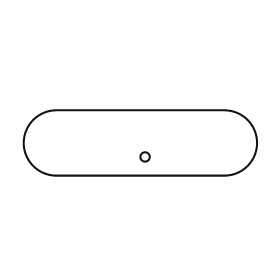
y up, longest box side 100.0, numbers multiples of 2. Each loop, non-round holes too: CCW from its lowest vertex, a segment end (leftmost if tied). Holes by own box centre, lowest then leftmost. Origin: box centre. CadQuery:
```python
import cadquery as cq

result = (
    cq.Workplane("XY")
    .moveTo(-36.0, -14.0)
    .lineTo(36.0, -14.0)
    .threePointArc((50.0, 0.0), (36.0, 14.0))
    .lineTo(-36.0, 14.0)
    .threePointArc((-50.0, 0.0), (-36.0, -14.0))
    .close()
    .moveTo(2.0, -6.0)
    .circle(2.0)
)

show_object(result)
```